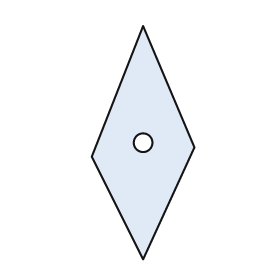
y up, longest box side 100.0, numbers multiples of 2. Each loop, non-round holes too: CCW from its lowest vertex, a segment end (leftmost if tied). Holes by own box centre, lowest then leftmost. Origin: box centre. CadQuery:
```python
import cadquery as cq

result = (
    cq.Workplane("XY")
    .moveTo(0.0, -50.0)
    .lineTo(22.0, -2.0)
    .lineTo(0.0, 50.0)
    .lineTo(-22.0, -6.0)
    .close()
    .moveTo(0.0, 0.0)
    .circle(4.0)
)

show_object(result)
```